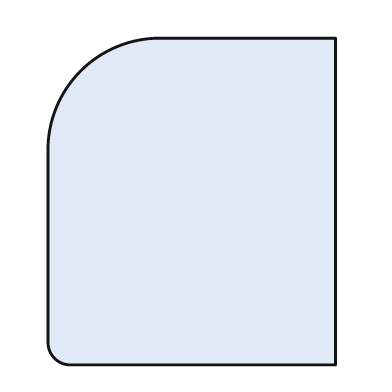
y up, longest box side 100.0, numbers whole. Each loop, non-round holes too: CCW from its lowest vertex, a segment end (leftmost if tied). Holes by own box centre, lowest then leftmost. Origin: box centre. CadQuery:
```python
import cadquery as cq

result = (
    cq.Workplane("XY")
    .moveTo(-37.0, -50.0)
    .lineTo(44.0, -50.0)
    .lineTo(44.0, 50.0)
    .lineTo(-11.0, 50.0)
    .threePointArc((-34.0, 40.0), (-44.0, 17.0))
    .lineTo(-44.0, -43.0)
    .threePointArc((-42.0, -48.0), (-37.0, -50.0))
    .close()
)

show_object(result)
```